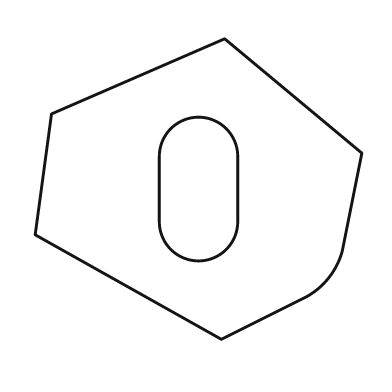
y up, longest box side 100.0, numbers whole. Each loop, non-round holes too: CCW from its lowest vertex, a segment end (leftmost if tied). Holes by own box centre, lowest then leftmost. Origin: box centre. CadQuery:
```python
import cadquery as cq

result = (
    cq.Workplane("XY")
    .moveTo(7.0, -46.0)
    .lineTo(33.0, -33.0)
    .threePointArc((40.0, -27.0), (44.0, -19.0))
    .lineTo(50.0, 11.0)
    .lineTo(8.0, 46.0)
    .lineTo(-45.0, 23.0)
    .lineTo(-50.0, -14.0)
    .close()
    .moveTo(-12.0, -10.0)
    .threePointArc((0.0, -22.0), (12.0, -10.0))
    .lineTo(12.0, 10.0)
    .threePointArc((0.0, 22.0), (-12.0, 10.0))
    .close()
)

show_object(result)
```